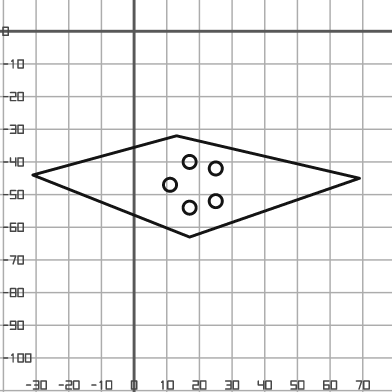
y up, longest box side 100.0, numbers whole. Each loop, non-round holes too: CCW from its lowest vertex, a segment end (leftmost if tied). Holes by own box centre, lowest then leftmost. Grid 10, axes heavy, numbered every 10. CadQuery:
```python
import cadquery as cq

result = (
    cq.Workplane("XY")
    .moveTo(17.0, -63.0)
    .lineTo(69.0, -45.0)
    .lineTo(13.0, -32.0)
    .lineTo(-31.0, -44.0)
    .close()
    .moveTo(17.0, -54.0)
    .circle(2.0)
    .moveTo(25.0, -52.0)
    .circle(2.0)
    .moveTo(11.0, -47.0)
    .circle(2.0)
    .moveTo(25.0, -42.0)
    .circle(2.0)
    .moveTo(17.0, -40.0)
    .circle(2.0)
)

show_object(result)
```